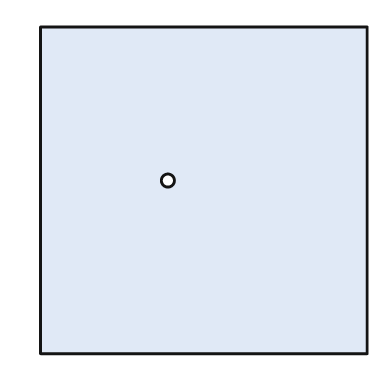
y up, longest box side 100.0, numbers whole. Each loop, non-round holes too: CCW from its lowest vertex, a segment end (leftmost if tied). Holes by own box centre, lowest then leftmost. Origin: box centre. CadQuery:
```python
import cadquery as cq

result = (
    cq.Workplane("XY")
    .moveTo(-50.0, -50.0)
    .lineTo(50.0, -50.0)
    .lineTo(50.0, 50.0)
    .lineTo(-50.0, 50.0)
    .close()
    .moveTo(-11.0, 3.0)
    .circle(2.0)
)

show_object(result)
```